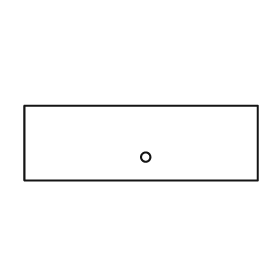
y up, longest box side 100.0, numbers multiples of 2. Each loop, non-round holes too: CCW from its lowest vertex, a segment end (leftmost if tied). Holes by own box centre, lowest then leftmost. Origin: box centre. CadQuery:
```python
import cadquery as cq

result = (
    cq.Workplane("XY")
    .moveTo(-50.0, -16.0)
    .lineTo(50.0, -16.0)
    .lineTo(50.0, 16.0)
    .lineTo(-50.0, 16.0)
    .close()
    .moveTo(2.0, -6.0)
    .circle(2.0)
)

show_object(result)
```